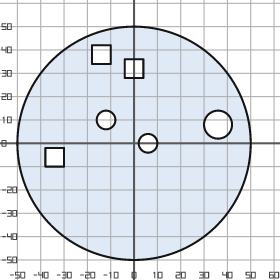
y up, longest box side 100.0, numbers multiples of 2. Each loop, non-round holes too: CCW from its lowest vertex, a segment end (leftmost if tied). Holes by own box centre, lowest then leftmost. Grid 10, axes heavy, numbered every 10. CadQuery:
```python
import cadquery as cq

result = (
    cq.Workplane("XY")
    .moveTo(0.0, 0.0)
    .circle(50.0)
    .moveTo(-38.0, -10.0)
    .lineTo(-30.0, -10.0)
    .lineTo(-30.0, -2.0)
    .lineTo(-38.0, -2.0)
    .close()
    .moveTo(6.0, 0.0)
    .circle(4.0)
    .moveTo(36.0, 8.0)
    .circle(6.0)
    .moveTo(-12.0, 10.0)
    .circle(4.0)
    .moveTo(-4.0, 28.0)
    .lineTo(4.0, 28.0)
    .lineTo(4.0, 36.0)
    .lineTo(-4.0, 36.0)
    .close()
    .moveTo(-18.0, 34.0)
    .lineTo(-10.0, 34.0)
    .lineTo(-10.0, 42.0)
    .lineTo(-18.0, 42.0)
    .close()
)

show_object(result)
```